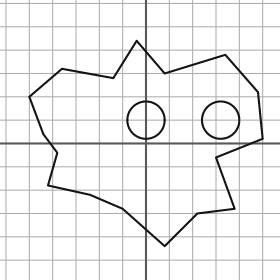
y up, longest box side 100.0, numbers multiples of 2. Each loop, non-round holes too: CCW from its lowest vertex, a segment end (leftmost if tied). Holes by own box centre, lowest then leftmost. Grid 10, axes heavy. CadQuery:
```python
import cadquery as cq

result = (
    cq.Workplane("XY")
    .moveTo(8.0, -44.0)
    .lineTo(22.0, -30.0)
    .lineTo(38.0, -28.0)
    .lineTo(30.0, -6.0)
    .lineTo(50.0, 2.0)
    .lineTo(48.0, 22.0)
    .lineTo(34.0, 38.0)
    .lineTo(8.0, 30.0)
    .lineTo(-4.0, 44.0)
    .lineTo(-14.0, 28.0)
    .lineTo(-36.0, 32.0)
    .lineTo(-50.0, 20.0)
    .lineTo(-44.0, 4.0)
    .lineTo(-38.0, -4.0)
    .lineTo(-42.0, -18.0)
    .lineTo(-24.0, -22.0)
    .lineTo(-10.0, -28.0)
    .close()
    .moveTo(0.0, 10.0)
    .circle(8.0)
    .moveTo(32.0, 10.0)
    .circle(8.0)
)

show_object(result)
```